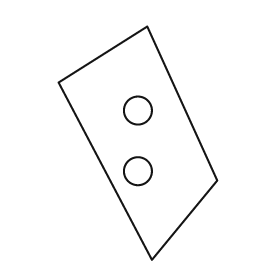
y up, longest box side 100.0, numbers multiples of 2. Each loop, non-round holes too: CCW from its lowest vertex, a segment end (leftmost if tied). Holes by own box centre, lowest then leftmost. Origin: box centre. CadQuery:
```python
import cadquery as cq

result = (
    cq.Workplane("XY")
    .moveTo(6.0, -50.0)
    .lineTo(34.0, -16.0)
    .lineTo(4.0, 50.0)
    .lineTo(-34.0, 26.0)
    .close()
    .moveTo(0.0, -12.0)
    .circle(6.0)
    .moveTo(0.0, 14.0)
    .circle(6.0)
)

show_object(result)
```